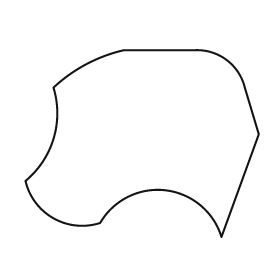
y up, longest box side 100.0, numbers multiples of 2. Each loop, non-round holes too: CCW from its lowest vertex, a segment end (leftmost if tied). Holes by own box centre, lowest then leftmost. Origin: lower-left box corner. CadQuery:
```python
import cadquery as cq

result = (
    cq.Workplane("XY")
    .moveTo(84.0, 0.0)
    .lineTo(100.0, 44.0)
    .lineTo(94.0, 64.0)
    .threePointArc((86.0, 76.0), (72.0, 80.0))
    .lineTo(42.0, 80.0)
    .threePointArc((26.0, 74.0), (12.0, 64.0))
    .threePointArc((12.0, 42.0), (0.0, 24.0))
    .threePointArc((12.0, 8.0), (32.0, 6.0))
    .threePointArc((60.0, 20.0), (84.0, 0.0))
    .close()
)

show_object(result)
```